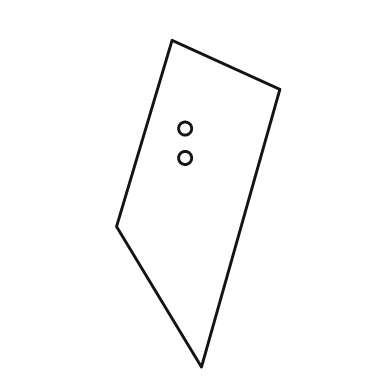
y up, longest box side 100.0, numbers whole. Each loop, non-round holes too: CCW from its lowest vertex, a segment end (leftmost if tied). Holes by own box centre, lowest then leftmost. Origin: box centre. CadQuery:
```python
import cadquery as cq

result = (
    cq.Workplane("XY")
    .moveTo(1.0, -50.0)
    .lineTo(25.0, 35.0)
    .lineTo(-8.0, 50.0)
    .lineTo(-25.0, -7.0)
    .close()
    .moveTo(-4.0, 14.0)
    .circle(2.0)
    .moveTo(-4.0, 23.0)
    .circle(2.0)
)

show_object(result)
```